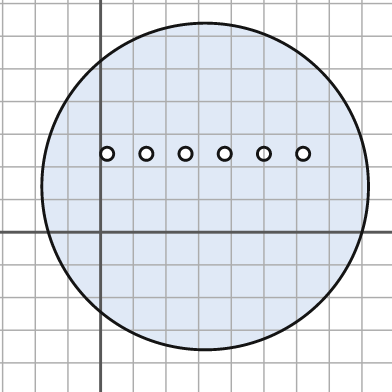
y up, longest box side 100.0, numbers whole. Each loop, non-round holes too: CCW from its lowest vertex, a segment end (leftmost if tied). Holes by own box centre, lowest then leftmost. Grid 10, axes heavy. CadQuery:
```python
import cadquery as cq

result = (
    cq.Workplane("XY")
    .moveTo(32.0, 14.0)
    .circle(50.0)
    .moveTo(2.0, 24.0)
    .circle(2.0)
    .moveTo(14.0, 24.0)
    .circle(2.0)
    .moveTo(26.0, 24.0)
    .circle(2.0)
    .moveTo(38.0, 24.0)
    .circle(2.0)
    .moveTo(50.0, 24.0)
    .circle(2.0)
    .moveTo(62.0, 24.0)
    .circle(2.0)
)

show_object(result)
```